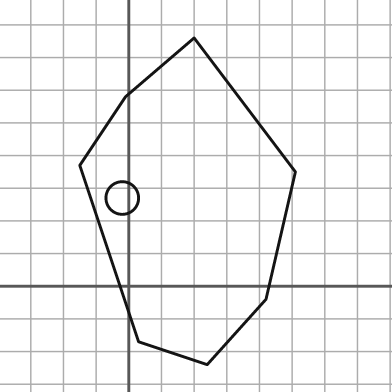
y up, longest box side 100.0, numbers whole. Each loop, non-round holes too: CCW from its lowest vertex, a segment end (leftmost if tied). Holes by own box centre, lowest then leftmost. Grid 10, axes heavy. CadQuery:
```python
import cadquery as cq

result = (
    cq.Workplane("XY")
    .moveTo(24.0, -24.0)
    .lineTo(42.0, -4.0)
    .lineTo(51.0, 35.0)
    .lineTo(20.0, 76.0)
    .lineTo(-1.0, 58.0)
    .lineTo(-15.0, 37.0)
    .lineTo(3.0, -17.0)
    .close()
    .moveTo(-2.0, 27.0)
    .circle(5.0)
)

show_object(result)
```